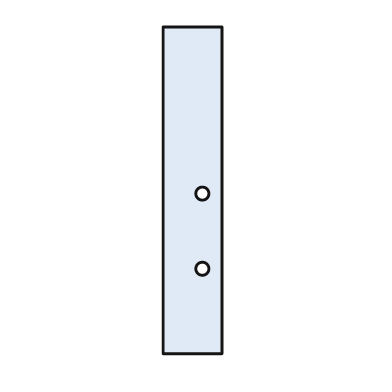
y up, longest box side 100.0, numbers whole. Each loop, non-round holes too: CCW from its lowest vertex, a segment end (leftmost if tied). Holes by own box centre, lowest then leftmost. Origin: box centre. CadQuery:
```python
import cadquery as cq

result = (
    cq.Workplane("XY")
    .moveTo(-9.0, -50.0)
    .lineTo(9.0, -50.0)
    .lineTo(9.0, 50.0)
    .lineTo(-9.0, 50.0)
    .close()
    .moveTo(3.0, -24.0)
    .circle(2.0)
    .moveTo(3.0, -1.0)
    .circle(2.0)
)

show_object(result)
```